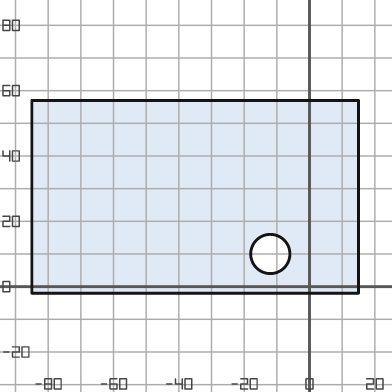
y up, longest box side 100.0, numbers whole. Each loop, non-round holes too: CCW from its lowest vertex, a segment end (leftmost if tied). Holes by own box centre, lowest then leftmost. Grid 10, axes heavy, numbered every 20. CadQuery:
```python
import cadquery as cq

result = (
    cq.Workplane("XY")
    .moveTo(-85.0, -2.0)
    .lineTo(15.0, -2.0)
    .lineTo(15.0, 57.0)
    .lineTo(-85.0, 57.0)
    .close()
    .moveTo(-12.0, 10.0)
    .circle(6.0)
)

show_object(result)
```